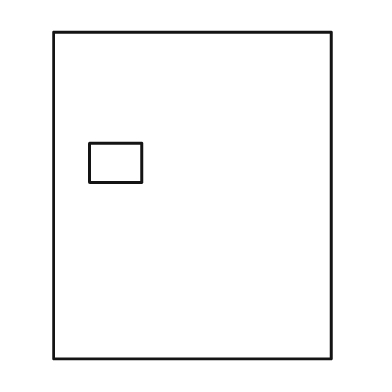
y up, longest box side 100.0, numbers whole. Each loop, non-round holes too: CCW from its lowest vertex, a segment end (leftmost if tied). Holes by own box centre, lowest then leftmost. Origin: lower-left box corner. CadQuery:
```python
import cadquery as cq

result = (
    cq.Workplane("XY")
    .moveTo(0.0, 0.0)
    .lineTo(85.0, 0.0)
    .lineTo(85.0, 100.0)
    .lineTo(0.0, 100.0)
    .close()
    .moveTo(11.0, 54.0)
    .lineTo(27.0, 54.0)
    .lineTo(27.0, 66.0)
    .lineTo(11.0, 66.0)
    .close()
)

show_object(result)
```